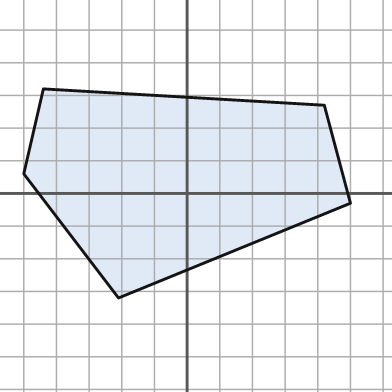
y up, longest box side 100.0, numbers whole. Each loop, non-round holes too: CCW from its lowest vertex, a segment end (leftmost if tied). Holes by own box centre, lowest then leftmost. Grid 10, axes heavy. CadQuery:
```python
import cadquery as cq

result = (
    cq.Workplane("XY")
    .moveTo(-21.0, -32.0)
    .lineTo(50.0, -3.0)
    .lineTo(42.0, 27.0)
    .lineTo(-44.0, 32.0)
    .lineTo(-50.0, 6.0)
    .close()
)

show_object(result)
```